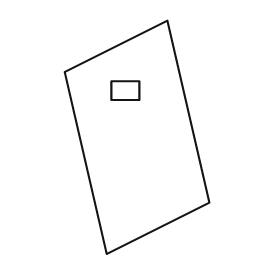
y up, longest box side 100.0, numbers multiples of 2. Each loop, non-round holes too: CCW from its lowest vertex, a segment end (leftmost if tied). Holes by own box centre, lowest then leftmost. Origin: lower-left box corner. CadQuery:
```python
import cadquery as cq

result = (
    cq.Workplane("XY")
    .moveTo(18.0, 0.0)
    .lineTo(62.0, 22.0)
    .lineTo(44.0, 100.0)
    .lineTo(0.0, 78.0)
    .close()
    .moveTo(20.0, 66.0)
    .lineTo(32.0, 66.0)
    .lineTo(32.0, 74.0)
    .lineTo(20.0, 74.0)
    .close()
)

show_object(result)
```